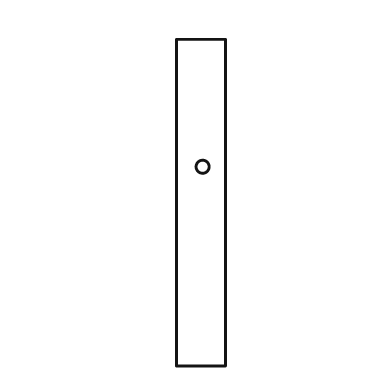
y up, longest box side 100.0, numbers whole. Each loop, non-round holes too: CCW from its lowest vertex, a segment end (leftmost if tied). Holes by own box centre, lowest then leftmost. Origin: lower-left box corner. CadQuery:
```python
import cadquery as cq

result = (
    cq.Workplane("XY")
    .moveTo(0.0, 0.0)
    .lineTo(15.0, 0.0)
    .lineTo(15.0, 100.0)
    .lineTo(0.0, 100.0)
    .close()
    .moveTo(8.0, 61.0)
    .circle(2.0)
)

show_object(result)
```